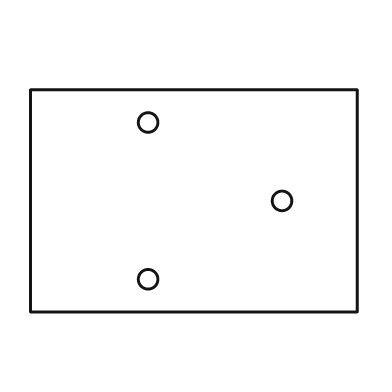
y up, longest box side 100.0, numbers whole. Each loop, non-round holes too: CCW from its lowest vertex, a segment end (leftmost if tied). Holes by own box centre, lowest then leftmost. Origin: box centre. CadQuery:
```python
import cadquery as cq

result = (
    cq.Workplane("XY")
    .moveTo(-50.0, -34.0)
    .lineTo(50.0, -34.0)
    .lineTo(50.0, 34.0)
    .lineTo(-50.0, 34.0)
    .close()
    .moveTo(-14.0, -24.0)
    .circle(3.0)
    .moveTo(27.0, 0.0)
    .circle(3.0)
    .moveTo(-14.0, 24.0)
    .circle(3.0)
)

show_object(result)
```